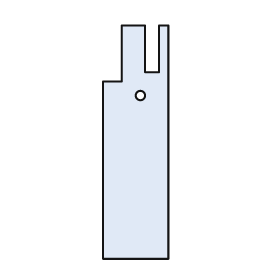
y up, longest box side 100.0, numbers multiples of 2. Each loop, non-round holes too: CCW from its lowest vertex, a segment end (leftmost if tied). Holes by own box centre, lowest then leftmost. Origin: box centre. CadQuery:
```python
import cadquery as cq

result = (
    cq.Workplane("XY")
    .moveTo(-14.0, -50.0)
    .lineTo(14.0, -50.0)
    .lineTo(14.0, 50.0)
    .lineTo(10.0, 50.0)
    .lineTo(10.0, 30.0)
    .lineTo(4.0, 30.0)
    .lineTo(4.0, 50.0)
    .lineTo(-6.0, 50.0)
    .lineTo(-6.0, 26.0)
    .lineTo(-14.0, 26.0)
    .close()
    .moveTo(2.0, 20.0)
    .circle(2.0)
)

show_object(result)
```